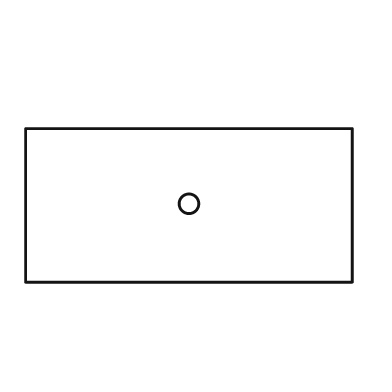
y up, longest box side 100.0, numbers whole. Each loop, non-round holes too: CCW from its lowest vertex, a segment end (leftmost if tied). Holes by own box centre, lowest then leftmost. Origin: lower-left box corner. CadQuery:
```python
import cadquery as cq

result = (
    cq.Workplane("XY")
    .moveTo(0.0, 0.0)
    .lineTo(100.0, 0.0)
    .lineTo(100.0, 47.0)
    .lineTo(0.0, 47.0)
    .close()
    .moveTo(50.0, 24.0)
    .circle(3.0)
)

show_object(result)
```